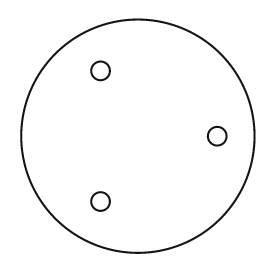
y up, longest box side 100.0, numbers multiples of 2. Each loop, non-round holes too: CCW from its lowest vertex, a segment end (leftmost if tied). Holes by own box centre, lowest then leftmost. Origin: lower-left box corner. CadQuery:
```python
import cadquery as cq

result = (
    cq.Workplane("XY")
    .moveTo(50.0, 50.0)
    .circle(50.0)
    .moveTo(34.0, 22.0)
    .circle(4.0)
    .moveTo(84.0, 50.0)
    .circle(4.0)
    .moveTo(34.0, 78.0)
    .circle(4.0)
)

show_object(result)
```